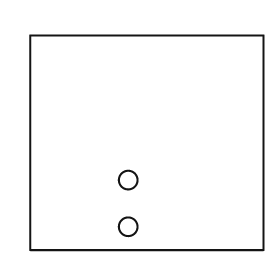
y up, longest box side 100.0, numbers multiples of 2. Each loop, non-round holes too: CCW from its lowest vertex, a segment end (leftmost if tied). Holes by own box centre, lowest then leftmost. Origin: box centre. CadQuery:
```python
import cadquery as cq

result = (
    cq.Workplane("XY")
    .moveTo(-50.0, -46.0)
    .lineTo(50.0, -46.0)
    .lineTo(50.0, 46.0)
    .lineTo(-50.0, 46.0)
    .close()
    .moveTo(-8.0, -36.0)
    .circle(4.0)
    .moveTo(-8.0, -16.0)
    .circle(4.0)
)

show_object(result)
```